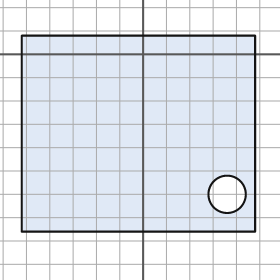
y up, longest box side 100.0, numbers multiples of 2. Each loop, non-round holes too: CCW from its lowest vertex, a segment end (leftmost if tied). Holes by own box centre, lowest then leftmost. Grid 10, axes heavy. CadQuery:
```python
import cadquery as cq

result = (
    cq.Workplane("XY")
    .moveTo(-52.0, -76.0)
    .lineTo(48.0, -76.0)
    .lineTo(48.0, 8.0)
    .lineTo(-52.0, 8.0)
    .close()
    .moveTo(36.0, -60.0)
    .circle(8.0)
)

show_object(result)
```